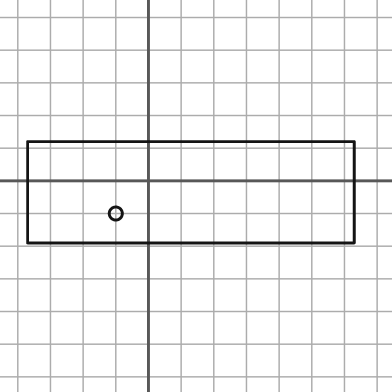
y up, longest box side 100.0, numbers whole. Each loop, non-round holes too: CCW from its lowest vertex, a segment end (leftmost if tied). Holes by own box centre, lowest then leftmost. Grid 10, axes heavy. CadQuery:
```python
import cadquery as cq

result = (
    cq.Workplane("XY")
    .moveTo(-37.0, -19.0)
    .lineTo(63.0, -19.0)
    .lineTo(63.0, 12.0)
    .lineTo(-37.0, 12.0)
    .close()
    .moveTo(-10.0, -10.0)
    .circle(2.0)
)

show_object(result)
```